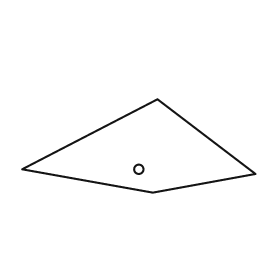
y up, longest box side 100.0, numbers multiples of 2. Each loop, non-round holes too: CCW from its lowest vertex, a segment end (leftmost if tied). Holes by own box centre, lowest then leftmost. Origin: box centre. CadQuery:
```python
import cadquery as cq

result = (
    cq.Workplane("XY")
    .moveTo(6.0, -20.0)
    .lineTo(50.0, -12.0)
    .lineTo(8.0, 20.0)
    .lineTo(-50.0, -10.0)
    .close()
    .moveTo(0.0, -10.0)
    .circle(2.0)
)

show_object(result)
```